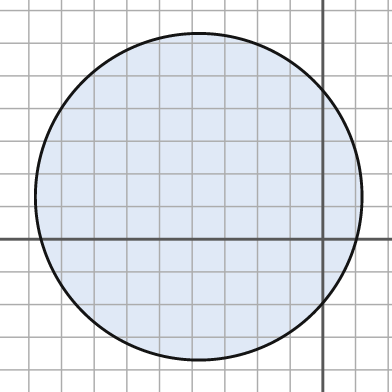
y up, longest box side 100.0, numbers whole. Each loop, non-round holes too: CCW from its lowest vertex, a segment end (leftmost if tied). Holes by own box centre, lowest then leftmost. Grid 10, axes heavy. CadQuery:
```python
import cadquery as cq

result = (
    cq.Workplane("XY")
    .moveTo(-38.0, 13.0)
    .circle(50.0)
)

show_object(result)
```